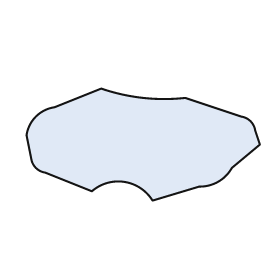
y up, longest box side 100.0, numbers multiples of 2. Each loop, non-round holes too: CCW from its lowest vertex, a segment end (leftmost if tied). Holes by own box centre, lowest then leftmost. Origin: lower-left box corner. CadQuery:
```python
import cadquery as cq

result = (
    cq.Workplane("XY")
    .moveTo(54.0, 0.0)
    .lineTo(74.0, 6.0)
    .threePointArc((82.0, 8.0), (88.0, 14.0))
    .lineTo(100.0, 24.0)
    .lineTo(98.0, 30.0)
    .threePointArc((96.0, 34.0), (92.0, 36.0))
    .lineTo(68.0, 44.0)
    .threePointArc((50.0, 44.0), (32.0, 48.0))
    .lineTo(12.0, 40.0)
    .threePointArc((4.0, 36.0), (0.0, 28.0))
    .lineTo(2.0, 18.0)
    .threePointArc((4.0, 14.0), (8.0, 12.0))
    .lineTo(28.0, 4.0)
    .threePointArc((42.0, 8.0), (54.0, 0.0))
    .close()
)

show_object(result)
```